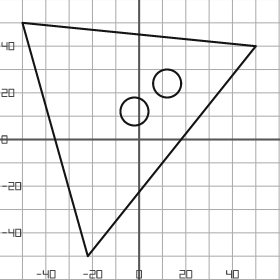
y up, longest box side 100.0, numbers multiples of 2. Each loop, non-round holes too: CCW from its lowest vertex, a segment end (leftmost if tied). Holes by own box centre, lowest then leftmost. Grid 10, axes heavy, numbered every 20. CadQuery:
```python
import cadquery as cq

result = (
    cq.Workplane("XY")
    .moveTo(-22.0, -50.0)
    .lineTo(50.0, 40.0)
    .lineTo(-50.0, 50.0)
    .close()
    .moveTo(-2.0, 12.0)
    .circle(6.0)
    .moveTo(12.0, 24.0)
    .circle(6.0)
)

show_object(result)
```